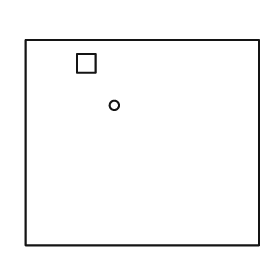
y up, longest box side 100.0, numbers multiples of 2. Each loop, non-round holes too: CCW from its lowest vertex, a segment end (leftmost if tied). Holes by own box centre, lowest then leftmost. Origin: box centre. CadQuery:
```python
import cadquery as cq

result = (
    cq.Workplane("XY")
    .moveTo(-50.0, -44.0)
    .lineTo(50.0, -44.0)
    .lineTo(50.0, 44.0)
    .lineTo(-50.0, 44.0)
    .close()
    .moveTo(-12.0, 16.0)
    .circle(2.0)
    .moveTo(-28.0, 30.0)
    .lineTo(-20.0, 30.0)
    .lineTo(-20.0, 38.0)
    .lineTo(-28.0, 38.0)
    .close()
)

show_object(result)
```